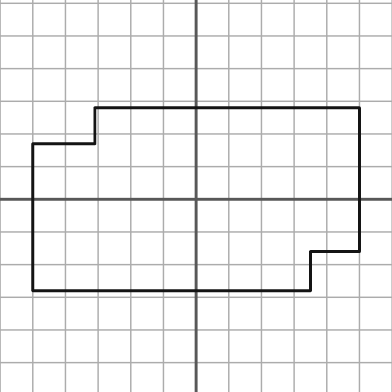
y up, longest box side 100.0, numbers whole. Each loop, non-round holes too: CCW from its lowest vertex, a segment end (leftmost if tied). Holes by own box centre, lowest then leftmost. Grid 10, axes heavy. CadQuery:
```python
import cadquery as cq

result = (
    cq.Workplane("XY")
    .moveTo(-50.0, -28.0)
    .lineTo(35.0, -28.0)
    .lineTo(35.0, -16.0)
    .lineTo(50.0, -16.0)
    .lineTo(50.0, 28.0)
    .lineTo(-31.0, 28.0)
    .lineTo(-31.0, 17.0)
    .lineTo(-50.0, 17.0)
    .close()
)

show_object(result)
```